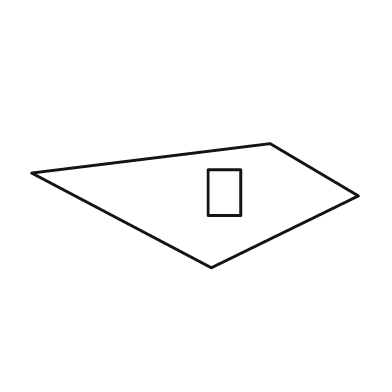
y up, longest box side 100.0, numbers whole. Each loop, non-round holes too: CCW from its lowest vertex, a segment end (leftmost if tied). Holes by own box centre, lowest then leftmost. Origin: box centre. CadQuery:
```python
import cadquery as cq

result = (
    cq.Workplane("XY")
    .moveTo(5.0, -19.0)
    .lineTo(50.0, 3.0)
    .lineTo(23.0, 19.0)
    .lineTo(-50.0, 10.0)
    .close()
    .moveTo(4.0, -3.0)
    .lineTo(14.0, -3.0)
    .lineTo(14.0, 11.0)
    .lineTo(4.0, 11.0)
    .close()
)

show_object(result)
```